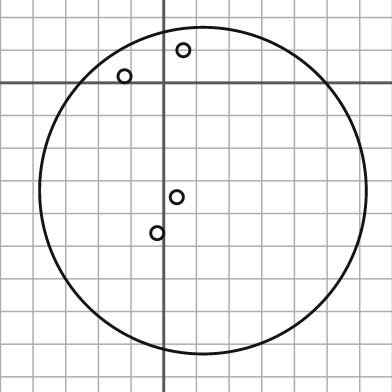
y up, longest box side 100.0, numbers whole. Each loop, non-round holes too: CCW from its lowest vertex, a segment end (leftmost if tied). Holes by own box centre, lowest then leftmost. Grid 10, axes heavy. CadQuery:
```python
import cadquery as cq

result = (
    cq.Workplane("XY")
    .moveTo(12.0, -33.0)
    .circle(50.0)
    .moveTo(-2.0, -46.0)
    .circle(2.0)
    .moveTo(4.0, -35.0)
    .circle(2.0)
    .moveTo(-12.0, 2.0)
    .circle(2.0)
    .moveTo(6.0, 10.0)
    .circle(2.0)
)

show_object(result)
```